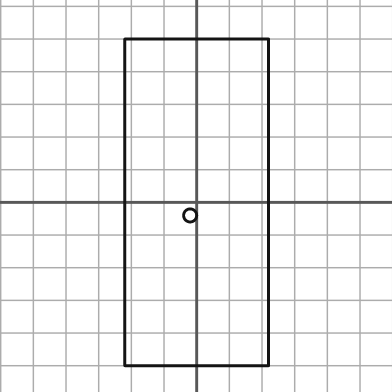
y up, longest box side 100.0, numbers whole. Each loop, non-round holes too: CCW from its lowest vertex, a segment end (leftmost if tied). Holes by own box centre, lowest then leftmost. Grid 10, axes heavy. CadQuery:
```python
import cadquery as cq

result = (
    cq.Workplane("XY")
    .moveTo(-22.0, -50.0)
    .lineTo(22.0, -50.0)
    .lineTo(22.0, 50.0)
    .lineTo(-22.0, 50.0)
    .close()
    .moveTo(-2.0, -4.0)
    .circle(2.0)
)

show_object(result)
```